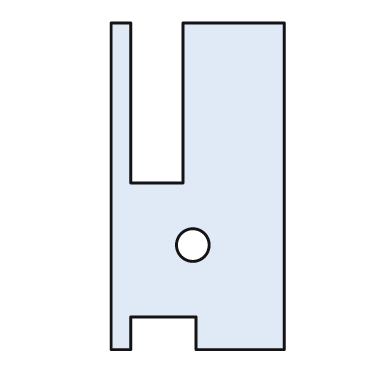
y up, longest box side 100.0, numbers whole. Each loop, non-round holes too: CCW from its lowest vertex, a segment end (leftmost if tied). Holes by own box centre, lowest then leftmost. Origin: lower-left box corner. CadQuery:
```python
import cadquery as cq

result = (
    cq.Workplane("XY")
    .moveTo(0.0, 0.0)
    .lineTo(6.0, 0.0)
    .lineTo(6.0, 10.0)
    .lineTo(26.0, 10.0)
    .lineTo(26.0, 0.0)
    .lineTo(53.0, 0.0)
    .lineTo(53.0, 100.0)
    .lineTo(22.0, 100.0)
    .lineTo(22.0, 51.0)
    .lineTo(6.0, 51.0)
    .lineTo(6.0, 100.0)
    .lineTo(0.0, 100.0)
    .close()
    .moveTo(25.0, 32.0)
    .circle(5.0)
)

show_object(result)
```